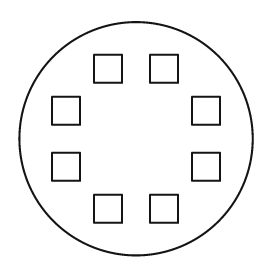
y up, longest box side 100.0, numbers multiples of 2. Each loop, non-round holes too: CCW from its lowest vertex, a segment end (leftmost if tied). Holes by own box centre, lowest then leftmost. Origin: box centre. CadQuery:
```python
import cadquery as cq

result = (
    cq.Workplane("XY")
    .moveTo(0.0, 0.0)
    .circle(50.0)
    .moveTo(-18.0, -36.0)
    .lineTo(-6.0, -36.0)
    .lineTo(-6.0, -24.0)
    .lineTo(-18.0, -24.0)
    .close()
    .moveTo(6.0, -36.0)
    .lineTo(18.0, -36.0)
    .lineTo(18.0, -24.0)
    .lineTo(6.0, -24.0)
    .close()
    .moveTo(-36.0, -18.0)
    .lineTo(-24.0, -18.0)
    .lineTo(-24.0, -6.0)
    .lineTo(-36.0, -6.0)
    .close()
    .moveTo(24.0, -18.0)
    .lineTo(36.0, -18.0)
    .lineTo(36.0, -6.0)
    .lineTo(24.0, -6.0)
    .close()
    .moveTo(-36.0, 6.0)
    .lineTo(-24.0, 6.0)
    .lineTo(-24.0, 18.0)
    .lineTo(-36.0, 18.0)
    .close()
    .moveTo(24.0, 6.0)
    .lineTo(36.0, 6.0)
    .lineTo(36.0, 18.0)
    .lineTo(24.0, 18.0)
    .close()
    .moveTo(-18.0, 24.0)
    .lineTo(-6.0, 24.0)
    .lineTo(-6.0, 36.0)
    .lineTo(-18.0, 36.0)
    .close()
    .moveTo(6.0, 24.0)
    .lineTo(18.0, 24.0)
    .lineTo(18.0, 36.0)
    .lineTo(6.0, 36.0)
    .close()
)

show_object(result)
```